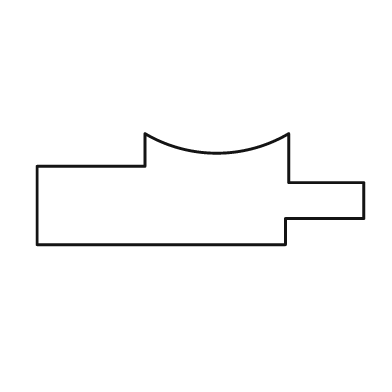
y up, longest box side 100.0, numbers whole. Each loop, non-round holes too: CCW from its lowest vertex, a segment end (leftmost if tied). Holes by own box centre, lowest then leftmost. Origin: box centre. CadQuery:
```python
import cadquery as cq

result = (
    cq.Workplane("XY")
    .moveTo(-50.0, -17.0)
    .lineTo(26.0, -17.0)
    .lineTo(26.0, -9.0)
    .lineTo(50.0, -9.0)
    .lineTo(50.0, 2.0)
    .lineTo(27.0, 2.0)
    .lineTo(27.0, 17.0)
    .threePointArc((5.0, 11.0), (-17.0, 17.0))
    .lineTo(-17.0, 7.0)
    .lineTo(-50.0, 7.0)
    .close()
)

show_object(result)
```